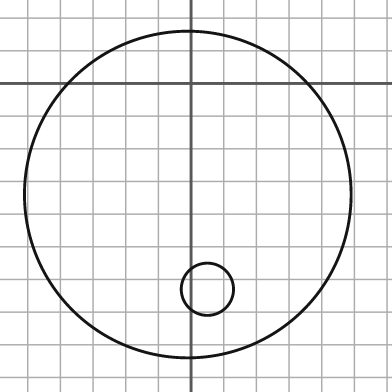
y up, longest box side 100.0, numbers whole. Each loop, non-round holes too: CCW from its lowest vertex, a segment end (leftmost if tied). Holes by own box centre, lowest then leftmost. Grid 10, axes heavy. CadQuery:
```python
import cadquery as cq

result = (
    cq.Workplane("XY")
    .moveTo(-1.0, -34.0)
    .circle(50.0)
    .moveTo(5.0, -63.0)
    .circle(8.0)
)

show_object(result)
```